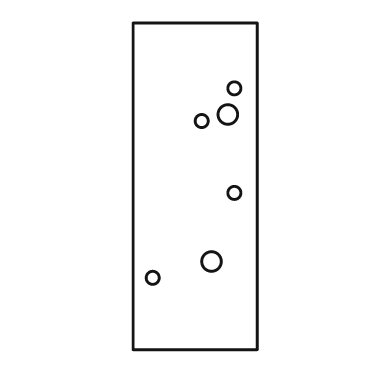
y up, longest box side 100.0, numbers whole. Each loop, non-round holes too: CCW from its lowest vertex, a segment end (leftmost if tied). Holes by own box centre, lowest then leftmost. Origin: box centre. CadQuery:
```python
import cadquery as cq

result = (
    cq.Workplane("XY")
    .moveTo(-19.0, -50.0)
    .lineTo(19.0, -50.0)
    .lineTo(19.0, 50.0)
    .lineTo(-19.0, 50.0)
    .close()
    .moveTo(-13.0, -28.0)
    .circle(2.0)
    .moveTo(5.0, -23.0)
    .circle(3.0)
    .moveTo(12.0, -2.0)
    .circle(2.0)
    .moveTo(2.0, 20.0)
    .circle(2.0)
    .moveTo(10.0, 22.0)
    .circle(3.0)
    .moveTo(12.0, 30.0)
    .circle(2.0)
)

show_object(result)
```